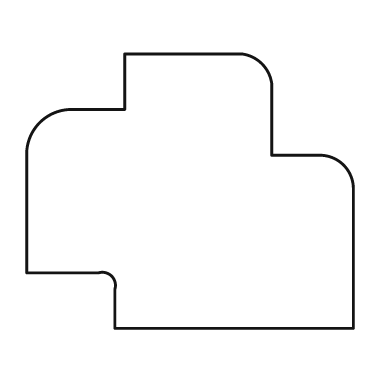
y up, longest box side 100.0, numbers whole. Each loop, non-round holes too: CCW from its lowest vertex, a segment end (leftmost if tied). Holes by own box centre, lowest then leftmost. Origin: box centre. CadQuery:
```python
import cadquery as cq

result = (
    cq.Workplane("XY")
    .moveTo(-23.0, -42.0)
    .lineTo(50.0, -42.0)
    .lineTo(50.0, 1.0)
    .threePointArc((47.0, 8.0), (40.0, 11.0))
    .lineTo(25.0, 11.0)
    .lineTo(25.0, 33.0)
    .threePointArc((22.0, 39.0), (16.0, 42.0))
    .lineTo(-20.0, 42.0)
    .lineTo(-20.0, 25.0)
    .lineTo(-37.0, 25.0)
    .threePointArc((-46.0, 21.0), (-50.0, 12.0))
    .lineTo(-50.0, -25.0)
    .lineTo(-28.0, -25.0)
    .threePointArc((-24.0, -26.0), (-23.0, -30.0))
    .close()
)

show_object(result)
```